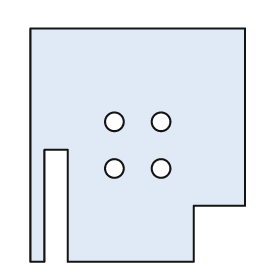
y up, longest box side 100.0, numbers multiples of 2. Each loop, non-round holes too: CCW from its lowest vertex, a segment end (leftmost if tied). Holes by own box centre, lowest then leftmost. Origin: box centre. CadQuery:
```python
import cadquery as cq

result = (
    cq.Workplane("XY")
    .moveTo(-46.0, -50.0)
    .lineTo(-40.0, -50.0)
    .lineTo(-40.0, -2.0)
    .lineTo(-30.0, -2.0)
    .lineTo(-30.0, -50.0)
    .lineTo(24.0, -50.0)
    .lineTo(24.0, -26.0)
    .lineTo(46.0, -26.0)
    .lineTo(46.0, 50.0)
    .lineTo(-46.0, 50.0)
    .close()
    .moveTo(-10.0, -10.0)
    .circle(4.0)
    .moveTo(10.0, -10.0)
    .circle(4.0)
    .moveTo(-10.0, 10.0)
    .circle(4.0)
    .moveTo(10.0, 10.0)
    .circle(4.0)
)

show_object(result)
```